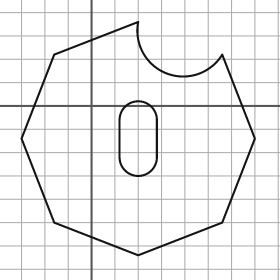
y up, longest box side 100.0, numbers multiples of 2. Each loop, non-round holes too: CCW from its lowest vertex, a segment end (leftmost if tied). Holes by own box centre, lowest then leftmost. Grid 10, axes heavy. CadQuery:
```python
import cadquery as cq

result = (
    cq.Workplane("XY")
    .moveTo(20.0, -64.0)
    .lineTo(56.0, -50.0)
    .lineTo(70.0, -14.0)
    .lineTo(56.0, 22.0)
    .threePointArc((32.0, 14.0), (20.0, 36.0))
    .lineTo(-16.0, 22.0)
    .lineTo(-30.0, -14.0)
    .lineTo(-16.0, -50.0)
    .close()
    .moveTo(12.0, -22.0)
    .threePointArc((20.0, -30.0), (28.0, -22.0))
    .lineTo(28.0, -6.0)
    .threePointArc((20.0, 2.0), (12.0, -6.0))
    .close()
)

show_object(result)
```